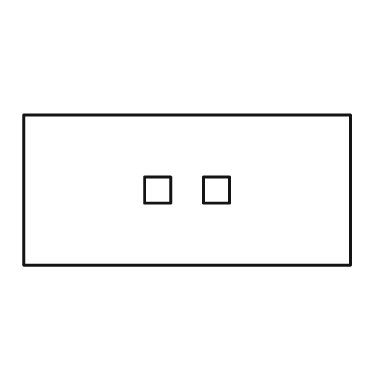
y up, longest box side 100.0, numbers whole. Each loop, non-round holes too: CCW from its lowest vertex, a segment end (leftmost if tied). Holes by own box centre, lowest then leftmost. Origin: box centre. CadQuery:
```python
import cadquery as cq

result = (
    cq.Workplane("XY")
    .moveTo(-50.0, -23.0)
    .lineTo(50.0, -23.0)
    .lineTo(50.0, 23.0)
    .lineTo(-50.0, 23.0)
    .close()
    .moveTo(-13.0, -4.0)
    .lineTo(-5.0, -4.0)
    .lineTo(-5.0, 4.0)
    .lineTo(-13.0, 4.0)
    .close()
    .moveTo(5.0, -4.0)
    .lineTo(13.0, -4.0)
    .lineTo(13.0, 4.0)
    .lineTo(5.0, 4.0)
    .close()
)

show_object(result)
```